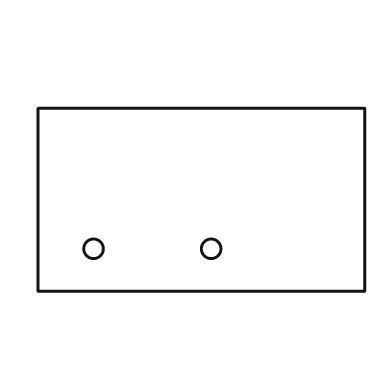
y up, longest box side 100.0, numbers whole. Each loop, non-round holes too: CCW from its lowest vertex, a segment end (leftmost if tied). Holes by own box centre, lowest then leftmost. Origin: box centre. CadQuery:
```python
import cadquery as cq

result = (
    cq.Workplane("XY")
    .moveTo(-50.0, -28.0)
    .lineTo(50.0, -28.0)
    .lineTo(50.0, 28.0)
    .lineTo(-50.0, 28.0)
    .close()
    .moveTo(-33.0, -15.0)
    .circle(3.0)
    .moveTo(3.0, -15.0)
    .circle(3.0)
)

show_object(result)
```